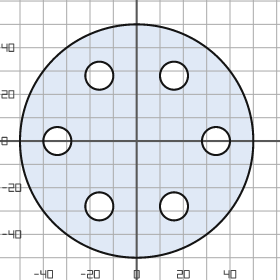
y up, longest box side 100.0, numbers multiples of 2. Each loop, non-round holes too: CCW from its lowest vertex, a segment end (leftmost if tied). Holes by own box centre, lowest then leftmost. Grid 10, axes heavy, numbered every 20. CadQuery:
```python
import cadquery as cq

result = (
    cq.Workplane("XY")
    .moveTo(0.0, 0.0)
    .circle(50.0)
    .moveTo(-16.0, -28.0)
    .circle(6.0)
    .moveTo(16.0, -28.0)
    .circle(6.0)
    .moveTo(-34.0, 0.0)
    .circle(6.0)
    .moveTo(34.0, 0.0)
    .circle(6.0)
    .moveTo(-16.0, 28.0)
    .circle(6.0)
    .moveTo(16.0, 28.0)
    .circle(6.0)
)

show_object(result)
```